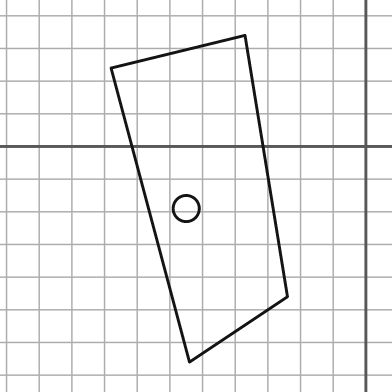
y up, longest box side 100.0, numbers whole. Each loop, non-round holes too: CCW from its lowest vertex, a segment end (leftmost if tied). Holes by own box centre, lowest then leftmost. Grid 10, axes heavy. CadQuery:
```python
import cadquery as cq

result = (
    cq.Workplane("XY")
    .moveTo(-54.0, -66.0)
    .lineTo(-24.0, -46.0)
    .lineTo(-37.0, 34.0)
    .lineTo(-78.0, 24.0)
    .close()
    .moveTo(-55.0, -19.0)
    .circle(4.0)
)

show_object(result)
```